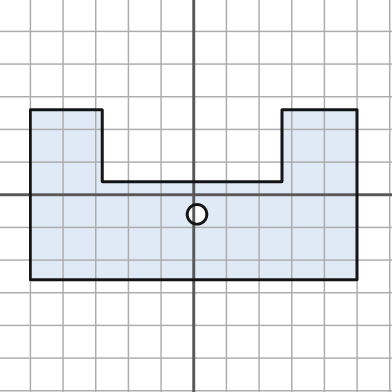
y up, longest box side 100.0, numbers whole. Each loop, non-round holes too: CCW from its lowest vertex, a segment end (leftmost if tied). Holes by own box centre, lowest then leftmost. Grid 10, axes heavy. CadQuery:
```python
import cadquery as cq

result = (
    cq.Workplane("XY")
    .moveTo(-50.0, -26.0)
    .lineTo(50.0, -26.0)
    .lineTo(50.0, 26.0)
    .lineTo(27.0, 26.0)
    .lineTo(27.0, 4.0)
    .lineTo(-28.0, 4.0)
    .lineTo(-28.0, 26.0)
    .lineTo(-50.0, 26.0)
    .close()
    .moveTo(1.0, -6.0)
    .circle(3.0)
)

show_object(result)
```